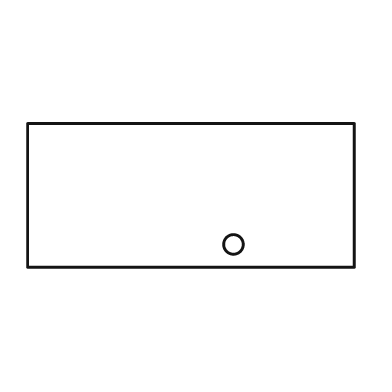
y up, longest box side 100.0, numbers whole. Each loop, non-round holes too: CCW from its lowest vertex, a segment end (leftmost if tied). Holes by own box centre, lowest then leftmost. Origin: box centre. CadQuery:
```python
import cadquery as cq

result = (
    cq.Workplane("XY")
    .moveTo(-50.0, -22.0)
    .lineTo(50.0, -22.0)
    .lineTo(50.0, 22.0)
    .lineTo(-50.0, 22.0)
    .close()
    .moveTo(13.0, -15.0)
    .circle(3.0)
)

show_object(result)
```